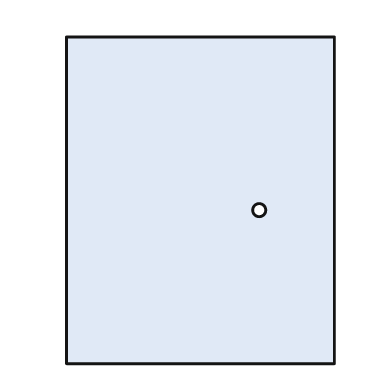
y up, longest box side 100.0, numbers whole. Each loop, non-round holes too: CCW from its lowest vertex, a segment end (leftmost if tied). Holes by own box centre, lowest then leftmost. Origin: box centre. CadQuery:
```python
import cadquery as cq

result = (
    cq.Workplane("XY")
    .moveTo(-41.0, -50.0)
    .lineTo(41.0, -50.0)
    .lineTo(41.0, 50.0)
    .lineTo(-41.0, 50.0)
    .close()
    .moveTo(18.0, -3.0)
    .circle(2.0)
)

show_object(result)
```